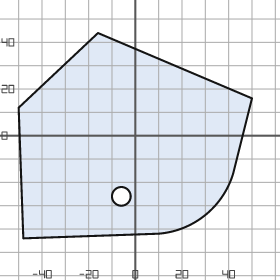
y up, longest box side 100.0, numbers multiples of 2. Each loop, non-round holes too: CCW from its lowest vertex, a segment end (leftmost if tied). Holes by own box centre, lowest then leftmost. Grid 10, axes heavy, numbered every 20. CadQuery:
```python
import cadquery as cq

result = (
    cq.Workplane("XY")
    .moveTo(-48.0, -44.0)
    .lineTo(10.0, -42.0)
    .threePointArc((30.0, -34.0), (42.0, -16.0))
    .lineTo(50.0, 16.0)
    .lineTo(-16.0, 44.0)
    .lineTo(-50.0, 12.0)
    .close()
    .moveTo(-6.0, -26.0)
    .circle(4.0)
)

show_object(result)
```